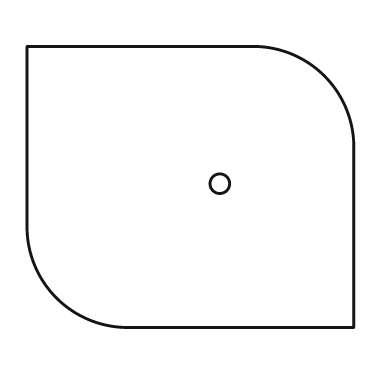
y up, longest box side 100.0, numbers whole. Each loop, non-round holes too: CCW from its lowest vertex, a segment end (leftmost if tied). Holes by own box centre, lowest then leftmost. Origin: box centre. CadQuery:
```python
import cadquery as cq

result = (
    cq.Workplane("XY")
    .moveTo(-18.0, -43.0)
    .lineTo(50.0, -43.0)
    .lineTo(50.0, 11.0)
    .threePointArc((41.0, 34.0), (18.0, 43.0))
    .lineTo(-50.0, 43.0)
    .lineTo(-50.0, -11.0)
    .threePointArc((-41.0, -34.0), (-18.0, -43.0))
    .close()
    .moveTo(9.0, 1.0)
    .circle(3.0)
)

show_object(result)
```